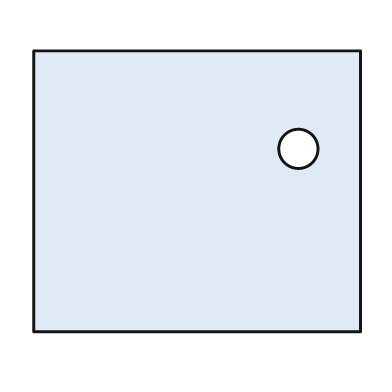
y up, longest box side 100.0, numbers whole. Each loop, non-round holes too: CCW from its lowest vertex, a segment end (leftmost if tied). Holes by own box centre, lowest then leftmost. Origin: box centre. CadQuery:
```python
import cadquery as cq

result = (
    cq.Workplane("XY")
    .moveTo(-50.0, -43.0)
    .lineTo(50.0, -43.0)
    .lineTo(50.0, 43.0)
    .lineTo(-50.0, 43.0)
    .close()
    .moveTo(31.0, 13.0)
    .circle(6.0)
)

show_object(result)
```